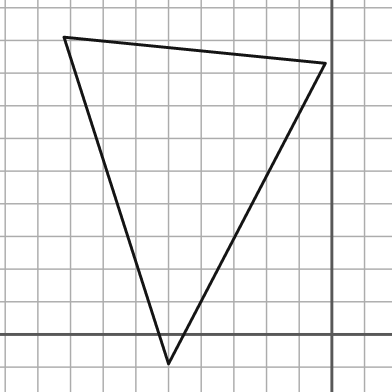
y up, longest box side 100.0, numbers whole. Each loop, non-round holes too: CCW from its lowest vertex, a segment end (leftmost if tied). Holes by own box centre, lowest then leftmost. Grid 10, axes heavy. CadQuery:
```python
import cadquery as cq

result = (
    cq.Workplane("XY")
    .moveTo(-50.0, -9.0)
    .lineTo(-2.0, 83.0)
    .lineTo(-82.0, 91.0)
    .close()
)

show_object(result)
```